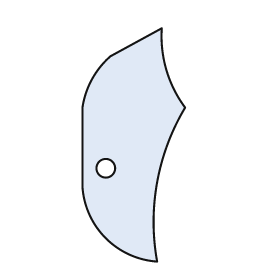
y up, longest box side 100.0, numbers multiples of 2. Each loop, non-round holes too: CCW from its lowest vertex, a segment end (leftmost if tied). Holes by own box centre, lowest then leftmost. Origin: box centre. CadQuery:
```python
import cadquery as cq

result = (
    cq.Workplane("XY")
    .moveTo(10.0, -50.0)
    .threePointArc((10.0, -16.0), (22.0, 16.0))
    .threePointArc((14.0, 32.0), (12.0, 50.0))
    .lineTo(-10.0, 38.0)
    .threePointArc((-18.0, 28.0), (-22.0, 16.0))
    .lineTo(-22.0, -18.0)
    .threePointArc((-12.0, -40.0), (10.0, -50.0))
    .close()
    .moveTo(-12.0, -10.0)
    .circle(4.0)
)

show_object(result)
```